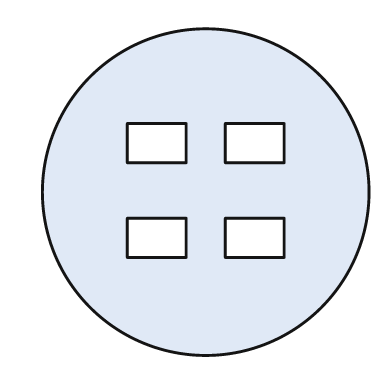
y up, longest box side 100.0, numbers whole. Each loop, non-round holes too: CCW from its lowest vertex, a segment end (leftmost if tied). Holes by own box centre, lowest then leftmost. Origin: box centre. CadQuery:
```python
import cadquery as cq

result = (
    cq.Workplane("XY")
    .moveTo(0.0, 0.0)
    .circle(50.0)
    .moveTo(-24.0, -20.0)
    .lineTo(-6.0, -20.0)
    .lineTo(-6.0, -8.0)
    .lineTo(-24.0, -8.0)
    .close()
    .moveTo(6.0, -20.0)
    .lineTo(24.0, -20.0)
    .lineTo(24.0, -8.0)
    .lineTo(6.0, -8.0)
    .close()
    .moveTo(-24.0, 9.0)
    .lineTo(-6.0, 9.0)
    .lineTo(-6.0, 21.0)
    .lineTo(-24.0, 21.0)
    .close()
    .moveTo(6.0, 9.0)
    .lineTo(24.0, 9.0)
    .lineTo(24.0, 21.0)
    .lineTo(6.0, 21.0)
    .close()
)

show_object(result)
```